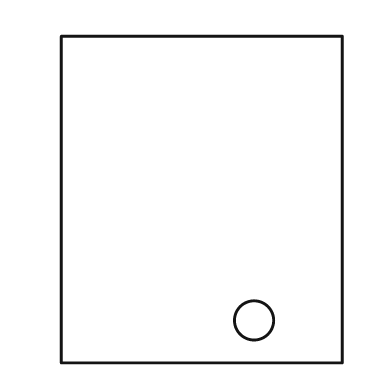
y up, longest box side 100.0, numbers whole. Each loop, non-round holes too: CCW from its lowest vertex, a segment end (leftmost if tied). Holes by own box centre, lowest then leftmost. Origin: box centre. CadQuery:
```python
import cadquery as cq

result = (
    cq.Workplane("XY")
    .moveTo(-43.0, -50.0)
    .lineTo(43.0, -50.0)
    .lineTo(43.0, 50.0)
    .lineTo(-43.0, 50.0)
    .close()
    .moveTo(16.0, -37.0)
    .circle(6.0)
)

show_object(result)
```